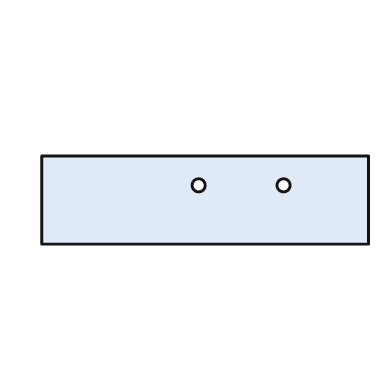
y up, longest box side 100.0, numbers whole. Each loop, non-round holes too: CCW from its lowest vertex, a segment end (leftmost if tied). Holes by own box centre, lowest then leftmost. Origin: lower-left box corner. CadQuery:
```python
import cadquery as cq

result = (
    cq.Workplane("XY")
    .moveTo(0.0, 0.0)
    .lineTo(100.0, 0.0)
    .lineTo(100.0, 27.0)
    .lineTo(0.0, 27.0)
    .close()
    .moveTo(48.0, 18.0)
    .circle(2.0)
    .moveTo(74.0, 18.0)
    .circle(2.0)
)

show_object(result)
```